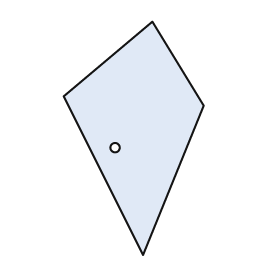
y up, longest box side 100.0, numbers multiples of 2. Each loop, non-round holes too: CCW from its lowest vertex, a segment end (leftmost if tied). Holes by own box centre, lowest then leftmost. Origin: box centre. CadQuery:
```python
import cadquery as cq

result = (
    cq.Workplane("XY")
    .moveTo(4.0, -50.0)
    .lineTo(30.0, 14.0)
    .lineTo(8.0, 50.0)
    .lineTo(-30.0, 18.0)
    .close()
    .moveTo(-8.0, -4.0)
    .circle(2.0)
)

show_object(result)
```